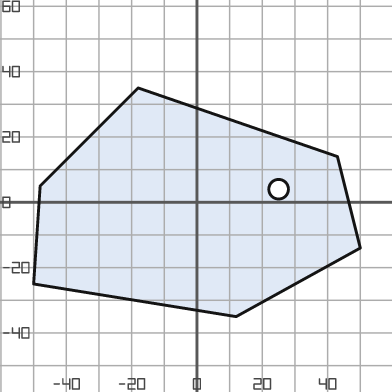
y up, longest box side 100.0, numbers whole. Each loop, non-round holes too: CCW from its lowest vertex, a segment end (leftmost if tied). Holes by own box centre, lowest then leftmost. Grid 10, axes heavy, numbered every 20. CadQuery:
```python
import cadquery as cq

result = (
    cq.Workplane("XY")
    .moveTo(12.0, -35.0)
    .lineTo(50.0, -14.0)
    .lineTo(43.0, 14.0)
    .lineTo(-18.0, 35.0)
    .lineTo(-48.0, 5.0)
    .lineTo(-50.0, -25.0)
    .close()
    .moveTo(25.0, 4.0)
    .circle(3.0)
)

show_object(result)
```